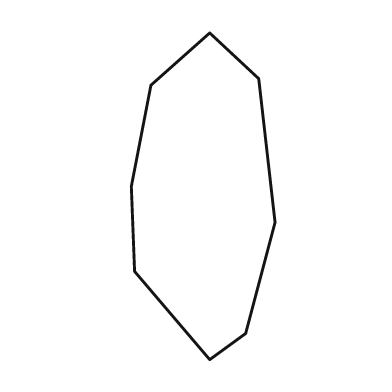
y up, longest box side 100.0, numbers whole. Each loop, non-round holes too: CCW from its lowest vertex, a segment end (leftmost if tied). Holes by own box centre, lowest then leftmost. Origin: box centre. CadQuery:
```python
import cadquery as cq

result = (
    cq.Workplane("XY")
    .moveTo(2.0, -50.0)
    .lineTo(13.0, -42.0)
    .lineTo(22.0, -8.0)
    .lineTo(17.0, 36.0)
    .lineTo(2.0, 50.0)
    .lineTo(-16.0, 34.0)
    .lineTo(-22.0, 3.0)
    .lineTo(-21.0, -23.0)
    .close()
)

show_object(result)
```